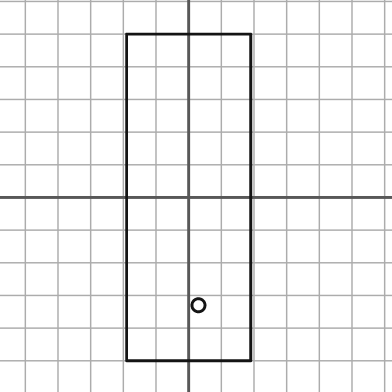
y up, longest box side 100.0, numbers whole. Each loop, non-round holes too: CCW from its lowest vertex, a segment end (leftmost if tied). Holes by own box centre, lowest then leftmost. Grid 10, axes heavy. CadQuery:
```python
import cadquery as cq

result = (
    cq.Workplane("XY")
    .moveTo(-19.0, -50.0)
    .lineTo(19.0, -50.0)
    .lineTo(19.0, 50.0)
    .lineTo(-19.0, 50.0)
    .close()
    .moveTo(3.0, -33.0)
    .circle(2.0)
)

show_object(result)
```